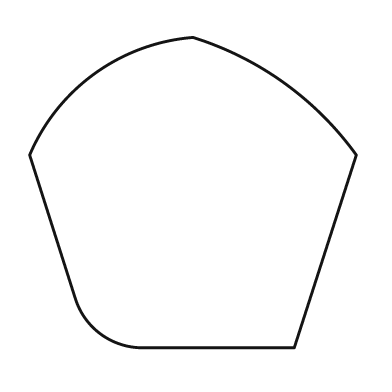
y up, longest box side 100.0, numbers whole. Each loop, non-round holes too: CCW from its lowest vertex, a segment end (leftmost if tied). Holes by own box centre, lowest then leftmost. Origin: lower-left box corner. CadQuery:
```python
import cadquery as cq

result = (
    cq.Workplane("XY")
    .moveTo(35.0, 0.0)
    .lineTo(81.0, 0.0)
    .lineTo(100.0, 59.0)
    .threePointArc((78.0, 81.0), (50.0, 95.0))
    .threePointArc((20.0, 84.0), (0.0, 59.0))
    .lineTo(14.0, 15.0)
    .threePointArc((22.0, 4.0), (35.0, 0.0))
    .close()
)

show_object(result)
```